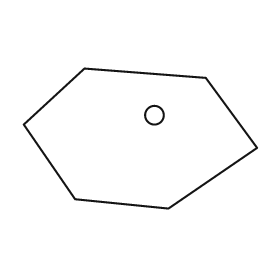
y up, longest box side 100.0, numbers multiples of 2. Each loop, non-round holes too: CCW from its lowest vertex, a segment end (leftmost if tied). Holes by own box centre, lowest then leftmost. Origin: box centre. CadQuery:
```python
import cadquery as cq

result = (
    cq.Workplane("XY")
    .moveTo(12.0, -30.0)
    .lineTo(50.0, -4.0)
    .lineTo(28.0, 26.0)
    .lineTo(-24.0, 30.0)
    .lineTo(-50.0, 6.0)
    .lineTo(-28.0, -26.0)
    .close()
    .moveTo(6.0, 10.0)
    .circle(4.0)
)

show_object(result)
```